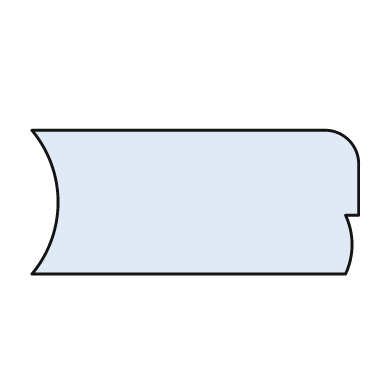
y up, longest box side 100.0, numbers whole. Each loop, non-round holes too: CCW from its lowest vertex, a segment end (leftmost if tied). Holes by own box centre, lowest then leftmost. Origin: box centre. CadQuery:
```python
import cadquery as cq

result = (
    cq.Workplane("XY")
    .moveTo(-50.0, -22.0)
    .lineTo(46.0, -22.0)
    .threePointArc((48.0, -13.0), (46.0, -4.0))
    .lineTo(50.0, -4.0)
    .lineTo(50.0, 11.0)
    .threePointArc((47.0, 19.0), (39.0, 22.0))
    .lineTo(-50.0, 22.0)
    .threePointArc((-42.0, 0.0), (-50.0, -22.0))
    .close()
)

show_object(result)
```